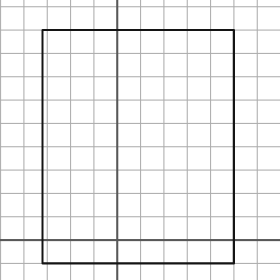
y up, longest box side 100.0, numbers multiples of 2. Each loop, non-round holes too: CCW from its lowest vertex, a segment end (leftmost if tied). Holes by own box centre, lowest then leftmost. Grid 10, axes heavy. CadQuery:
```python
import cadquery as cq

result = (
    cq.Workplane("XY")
    .moveTo(-32.0, -10.0)
    .lineTo(50.0, -10.0)
    .lineTo(50.0, 90.0)
    .lineTo(-32.0, 90.0)
    .close()
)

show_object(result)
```